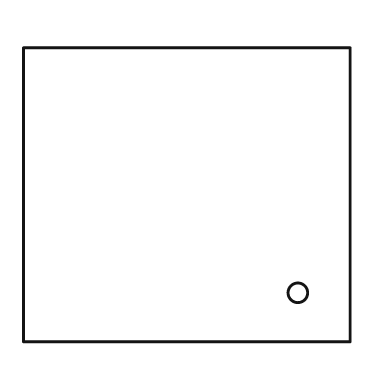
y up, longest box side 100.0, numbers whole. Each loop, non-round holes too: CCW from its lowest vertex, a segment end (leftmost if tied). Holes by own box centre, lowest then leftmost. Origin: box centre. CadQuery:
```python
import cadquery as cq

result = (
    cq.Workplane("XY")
    .moveTo(-50.0, -45.0)
    .lineTo(50.0, -45.0)
    .lineTo(50.0, 45.0)
    .lineTo(-50.0, 45.0)
    .close()
    .moveTo(34.0, -30.0)
    .circle(3.0)
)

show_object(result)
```